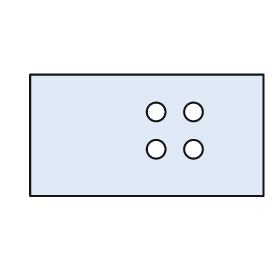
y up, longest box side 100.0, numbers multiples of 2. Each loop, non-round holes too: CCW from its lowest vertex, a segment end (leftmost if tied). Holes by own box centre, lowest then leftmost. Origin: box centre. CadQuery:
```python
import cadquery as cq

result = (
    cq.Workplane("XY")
    .moveTo(-50.0, -26.0)
    .lineTo(50.0, -26.0)
    .lineTo(50.0, 26.0)
    .lineTo(-50.0, 26.0)
    .close()
    .moveTo(4.0, -6.0)
    .circle(4.0)
    .moveTo(20.0, -6.0)
    .circle(4.0)
    .moveTo(4.0, 10.0)
    .circle(4.0)
    .moveTo(20.0, 10.0)
    .circle(4.0)
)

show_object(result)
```